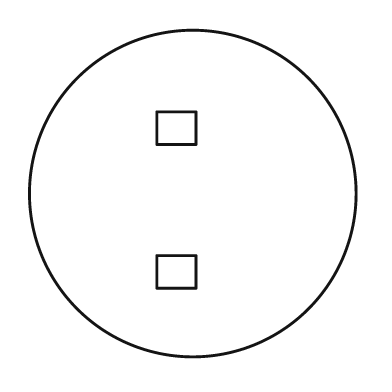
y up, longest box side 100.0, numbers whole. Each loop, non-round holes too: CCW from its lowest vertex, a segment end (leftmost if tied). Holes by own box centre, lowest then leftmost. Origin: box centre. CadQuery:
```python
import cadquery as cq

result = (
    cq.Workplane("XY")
    .moveTo(0.0, 0.0)
    .circle(50.0)
    .moveTo(-11.0, -29.0)
    .lineTo(1.0, -29.0)
    .lineTo(1.0, -19.0)
    .lineTo(-11.0, -19.0)
    .close()
    .moveTo(-11.0, 15.0)
    .lineTo(1.0, 15.0)
    .lineTo(1.0, 25.0)
    .lineTo(-11.0, 25.0)
    .close()
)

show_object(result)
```